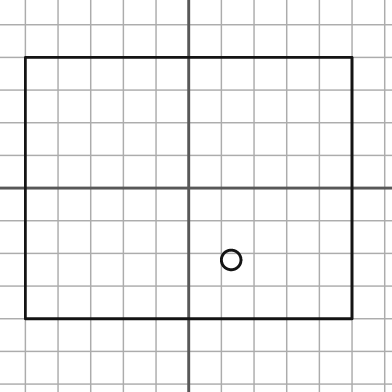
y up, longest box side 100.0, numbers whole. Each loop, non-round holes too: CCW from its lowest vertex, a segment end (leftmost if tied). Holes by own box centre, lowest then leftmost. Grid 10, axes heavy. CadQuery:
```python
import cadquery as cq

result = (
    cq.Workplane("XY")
    .moveTo(-50.0, -40.0)
    .lineTo(50.0, -40.0)
    .lineTo(50.0, 40.0)
    .lineTo(-50.0, 40.0)
    .close()
    .moveTo(13.0, -22.0)
    .circle(3.0)
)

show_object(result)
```